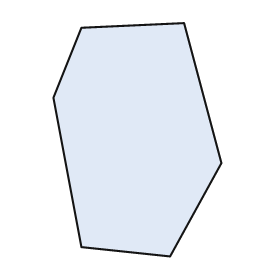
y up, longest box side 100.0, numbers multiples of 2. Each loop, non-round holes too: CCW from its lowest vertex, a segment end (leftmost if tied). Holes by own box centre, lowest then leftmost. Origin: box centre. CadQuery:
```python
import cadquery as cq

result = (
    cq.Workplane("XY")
    .moveTo(14.0, -50.0)
    .lineTo(36.0, -10.0)
    .lineTo(20.0, 50.0)
    .lineTo(-24.0, 48.0)
    .lineTo(-36.0, 18.0)
    .lineTo(-24.0, -46.0)
    .close()
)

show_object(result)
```